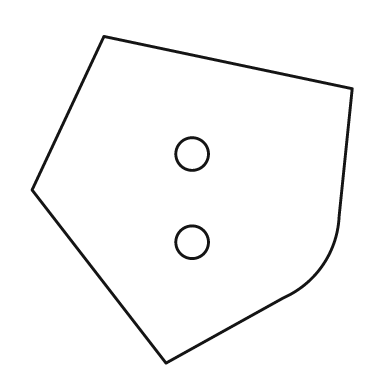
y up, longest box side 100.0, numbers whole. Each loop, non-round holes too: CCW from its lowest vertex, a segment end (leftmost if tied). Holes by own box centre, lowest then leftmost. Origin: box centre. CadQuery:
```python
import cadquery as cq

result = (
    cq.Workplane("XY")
    .moveTo(-8.0, -50.0)
    .lineTo(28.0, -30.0)
    .threePointArc((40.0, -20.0), (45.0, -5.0))
    .lineTo(49.0, 34.0)
    .lineTo(-27.0, 50.0)
    .lineTo(-49.0, 3.0)
    .close()
    .moveTo(0.0, -13.0)
    .circle(5.0)
    .moveTo(0.0, 14.0)
    .circle(5.0)
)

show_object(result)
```